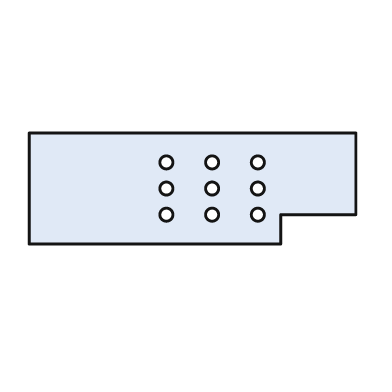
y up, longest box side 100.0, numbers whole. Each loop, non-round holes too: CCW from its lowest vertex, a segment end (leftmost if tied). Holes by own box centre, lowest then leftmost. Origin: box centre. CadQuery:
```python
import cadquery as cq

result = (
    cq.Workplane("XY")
    .moveTo(-50.0, -17.0)
    .lineTo(27.0, -17.0)
    .lineTo(27.0, -8.0)
    .lineTo(50.0, -8.0)
    .lineTo(50.0, 17.0)
    .lineTo(-50.0, 17.0)
    .close()
    .moveTo(-8.0, -8.0)
    .circle(2.0)
    .moveTo(6.0, -8.0)
    .circle(2.0)
    .moveTo(20.0, -8.0)
    .circle(2.0)
    .moveTo(-8.0, 0.0)
    .circle(2.0)
    .moveTo(6.0, 0.0)
    .circle(2.0)
    .moveTo(20.0, 0.0)
    .circle(2.0)
    .moveTo(-8.0, 8.0)
    .circle(2.0)
    .moveTo(6.0, 8.0)
    .circle(2.0)
    .moveTo(20.0, 8.0)
    .circle(2.0)
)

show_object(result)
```